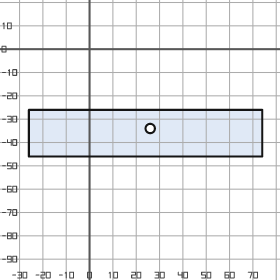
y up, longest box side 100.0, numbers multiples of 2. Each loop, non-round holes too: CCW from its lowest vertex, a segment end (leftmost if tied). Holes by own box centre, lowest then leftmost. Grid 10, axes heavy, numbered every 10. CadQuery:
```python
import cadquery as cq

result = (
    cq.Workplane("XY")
    .moveTo(-26.0, -46.0)
    .lineTo(74.0, -46.0)
    .lineTo(74.0, -26.0)
    .lineTo(-26.0, -26.0)
    .close()
    .moveTo(26.0, -34.0)
    .circle(2.0)
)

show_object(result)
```